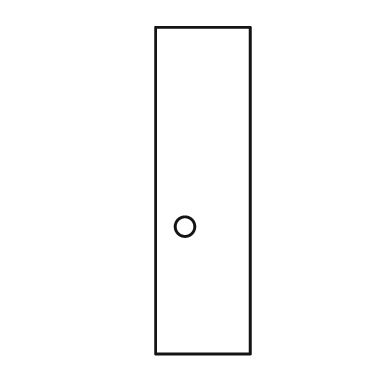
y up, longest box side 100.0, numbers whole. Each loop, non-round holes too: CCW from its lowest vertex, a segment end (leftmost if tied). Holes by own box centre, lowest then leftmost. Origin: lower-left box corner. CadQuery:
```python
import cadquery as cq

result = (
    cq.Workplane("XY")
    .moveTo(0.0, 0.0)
    .lineTo(29.0, 0.0)
    .lineTo(29.0, 100.0)
    .lineTo(0.0, 100.0)
    .close()
    .moveTo(9.0, 39.0)
    .circle(3.0)
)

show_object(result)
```